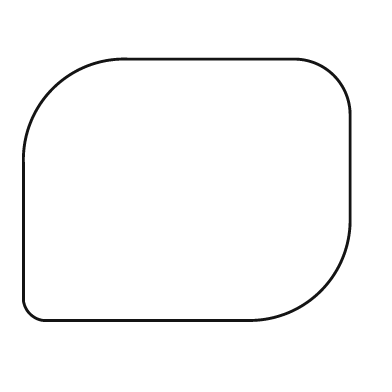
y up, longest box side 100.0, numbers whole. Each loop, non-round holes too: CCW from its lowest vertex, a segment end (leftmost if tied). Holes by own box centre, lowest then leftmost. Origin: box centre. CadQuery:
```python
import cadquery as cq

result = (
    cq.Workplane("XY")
    .moveTo(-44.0, -40.0)
    .lineTo(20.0, -40.0)
    .threePointArc((41.0, -31.0), (50.0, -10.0))
    .lineTo(50.0, 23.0)
    .threePointArc((45.0, 35.0), (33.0, 40.0))
    .lineTo(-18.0, 40.0)
    .threePointArc((-41.0, 31.0), (-50.0, 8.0))
    .lineTo(-50.0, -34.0)
    .threePointArc((-48.0, -38.0), (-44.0, -40.0))
    .close()
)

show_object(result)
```